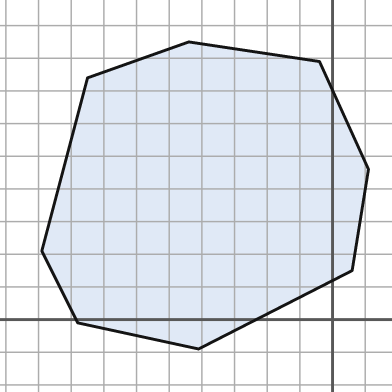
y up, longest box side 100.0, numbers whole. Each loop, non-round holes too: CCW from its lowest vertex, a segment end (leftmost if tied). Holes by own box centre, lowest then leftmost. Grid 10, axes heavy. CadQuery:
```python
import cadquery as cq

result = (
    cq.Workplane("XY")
    .moveTo(-41.0, -9.0)
    .lineTo(6.0, 15.0)
    .lineTo(11.0, 46.0)
    .lineTo(-4.0, 79.0)
    .lineTo(-44.0, 85.0)
    .lineTo(-75.0, 74.0)
    .lineTo(-89.0, 21.0)
    .lineTo(-78.0, -1.0)
    .close()
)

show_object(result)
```